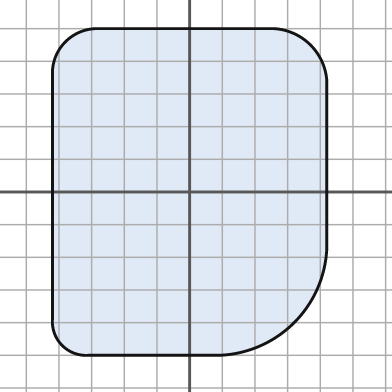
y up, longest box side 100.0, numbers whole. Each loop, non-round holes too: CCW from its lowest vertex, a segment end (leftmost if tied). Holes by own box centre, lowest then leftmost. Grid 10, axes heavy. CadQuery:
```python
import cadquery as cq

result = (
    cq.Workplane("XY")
    .moveTo(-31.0, -50.0)
    .lineTo(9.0, -50.0)
    .threePointArc((32.0, -40.0), (42.0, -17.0))
    .lineTo(42.0, 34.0)
    .threePointArc((37.0, 45.0), (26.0, 50.0))
    .lineTo(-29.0, 50.0)
    .threePointArc((-38.0, 46.0), (-42.0, 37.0))
    .lineTo(-42.0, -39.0)
    .threePointArc((-39.0, -47.0), (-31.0, -50.0))
    .close()
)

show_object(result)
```